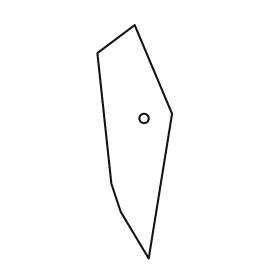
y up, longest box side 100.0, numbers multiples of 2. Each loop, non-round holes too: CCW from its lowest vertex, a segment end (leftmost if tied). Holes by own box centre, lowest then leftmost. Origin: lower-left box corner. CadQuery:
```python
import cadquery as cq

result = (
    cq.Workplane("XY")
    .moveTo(22.0, 0.0)
    .lineTo(32.0, 62.0)
    .lineTo(16.0, 100.0)
    .lineTo(0.0, 88.0)
    .lineTo(6.0, 32.0)
    .lineTo(10.0, 20.0)
    .close()
    .moveTo(20.0, 60.0)
    .circle(2.0)
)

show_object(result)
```